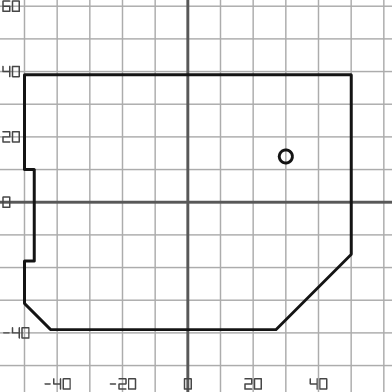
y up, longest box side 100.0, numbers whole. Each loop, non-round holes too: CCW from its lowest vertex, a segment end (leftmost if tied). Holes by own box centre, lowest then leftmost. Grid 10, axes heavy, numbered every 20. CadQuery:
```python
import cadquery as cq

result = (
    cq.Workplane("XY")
    .moveTo(-42.0, -39.0)
    .lineTo(27.0, -39.0)
    .lineTo(50.0, -16.0)
    .lineTo(50.0, 39.0)
    .lineTo(-50.0, 39.0)
    .lineTo(-50.0, 10.0)
    .lineTo(-47.0, 10.0)
    .lineTo(-47.0, -18.0)
    .lineTo(-50.0, -18.0)
    .lineTo(-50.0, -31.0)
    .close()
    .moveTo(30.0, 14.0)
    .circle(2.0)
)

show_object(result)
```